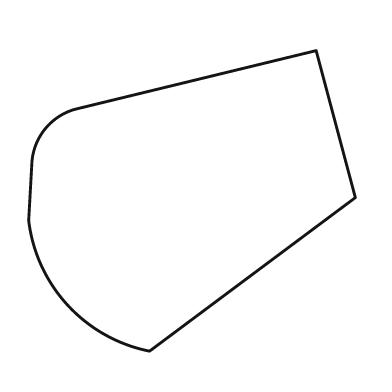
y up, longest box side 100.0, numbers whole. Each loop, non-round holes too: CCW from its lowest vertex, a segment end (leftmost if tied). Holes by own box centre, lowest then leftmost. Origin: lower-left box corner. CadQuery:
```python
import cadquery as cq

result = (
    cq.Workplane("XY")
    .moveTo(37.0, 0.0)
    .lineTo(100.0, 47.0)
    .lineTo(88.0, 92.0)
    .lineTo(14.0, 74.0)
    .threePointArc((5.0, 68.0), (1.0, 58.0))
    .lineTo(0.0, 40.0)
    .threePointArc((12.0, 14.0), (37.0, 0.0))
    .close()
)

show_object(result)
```